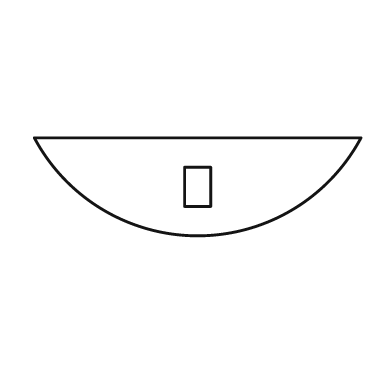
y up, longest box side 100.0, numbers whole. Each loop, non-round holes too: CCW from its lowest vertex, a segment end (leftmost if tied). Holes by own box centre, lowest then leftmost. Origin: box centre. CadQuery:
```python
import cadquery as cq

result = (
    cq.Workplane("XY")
    .moveTo(-50.0, 15.0)
    .threePointArc((0.0, -15.0), (50.0, 15.0))
    .close()
    .moveTo(-4.0, -6.0)
    .lineTo(4.0, -6.0)
    .lineTo(4.0, 6.0)
    .lineTo(-4.0, 6.0)
    .close()
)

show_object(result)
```